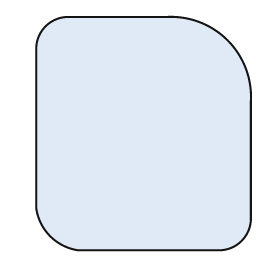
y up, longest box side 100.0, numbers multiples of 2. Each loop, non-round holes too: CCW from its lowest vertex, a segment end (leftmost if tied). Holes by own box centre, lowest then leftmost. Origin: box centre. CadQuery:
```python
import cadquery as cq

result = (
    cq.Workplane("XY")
    .moveTo(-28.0, -50.0)
    .lineTo(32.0, -50.0)
    .threePointArc((42.0, -46.0), (46.0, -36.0))
    .lineTo(46.0, 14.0)
    .threePointArc((36.0, 40.0), (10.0, 50.0))
    .lineTo(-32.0, 50.0)
    .threePointArc((-42.0, 46.0), (-46.0, 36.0))
    .lineTo(-46.0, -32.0)
    .threePointArc((-40.0, -44.0), (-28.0, -50.0))
    .close()
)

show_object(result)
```